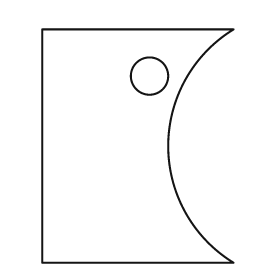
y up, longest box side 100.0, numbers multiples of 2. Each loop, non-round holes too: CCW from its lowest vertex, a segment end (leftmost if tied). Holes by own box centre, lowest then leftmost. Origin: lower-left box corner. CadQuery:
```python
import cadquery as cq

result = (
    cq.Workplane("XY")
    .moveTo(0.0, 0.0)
    .lineTo(82.0, 0.0)
    .threePointArc((54.0, 50.0), (82.0, 100.0))
    .lineTo(0.0, 100.0)
    .close()
    .moveTo(46.0, 80.0)
    .circle(8.0)
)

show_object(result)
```